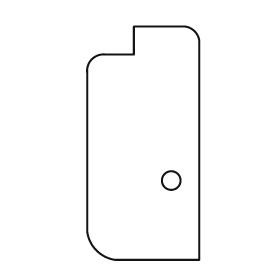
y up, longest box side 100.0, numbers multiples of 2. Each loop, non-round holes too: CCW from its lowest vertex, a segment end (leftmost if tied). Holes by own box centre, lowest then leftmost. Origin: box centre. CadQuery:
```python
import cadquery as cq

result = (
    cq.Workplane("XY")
    .moveTo(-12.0, -50.0)
    .lineTo(24.0, -50.0)
    .lineTo(24.0, 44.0)
    .threePointArc((22.0, 48.0), (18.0, 50.0))
    .lineTo(-4.0, 50.0)
    .lineTo(-4.0, 38.0)
    .lineTo(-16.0, 38.0)
    .threePointArc((-22.0, 36.0), (-24.0, 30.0))
    .lineTo(-24.0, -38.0)
    .threePointArc((-20.0, -46.0), (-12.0, -50.0))
    .close()
    .moveTo(12.0, -16.0)
    .circle(4.0)
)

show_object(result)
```